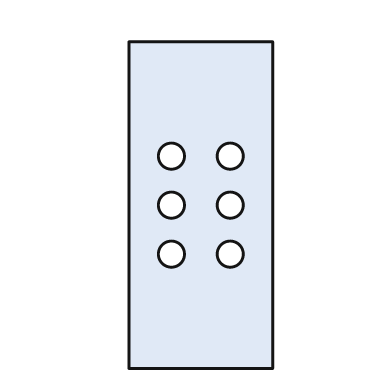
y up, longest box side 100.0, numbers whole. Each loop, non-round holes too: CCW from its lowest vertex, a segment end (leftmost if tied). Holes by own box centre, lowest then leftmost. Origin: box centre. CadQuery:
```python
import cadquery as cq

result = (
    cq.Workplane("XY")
    .moveTo(-22.0, -50.0)
    .lineTo(22.0, -50.0)
    .lineTo(22.0, 50.0)
    .lineTo(-22.0, 50.0)
    .close()
    .moveTo(-9.0, -15.0)
    .circle(4.0)
    .moveTo(9.0, -15.0)
    .circle(4.0)
    .moveTo(-9.0, 0.0)
    .circle(4.0)
    .moveTo(9.0, 0.0)
    .circle(4.0)
    .moveTo(-9.0, 15.0)
    .circle(4.0)
    .moveTo(9.0, 15.0)
    .circle(4.0)
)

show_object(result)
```